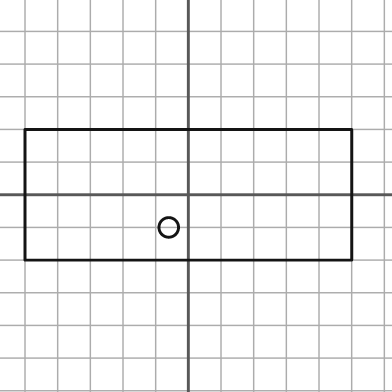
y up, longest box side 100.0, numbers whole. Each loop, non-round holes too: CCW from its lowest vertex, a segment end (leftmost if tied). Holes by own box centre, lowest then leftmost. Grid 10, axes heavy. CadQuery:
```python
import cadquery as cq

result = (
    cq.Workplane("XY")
    .moveTo(-50.0, -20.0)
    .lineTo(50.0, -20.0)
    .lineTo(50.0, 20.0)
    .lineTo(-50.0, 20.0)
    .close()
    .moveTo(-6.0, -10.0)
    .circle(3.0)
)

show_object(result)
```